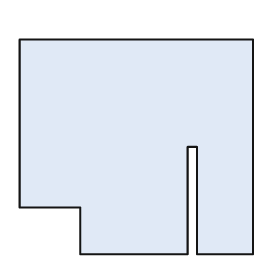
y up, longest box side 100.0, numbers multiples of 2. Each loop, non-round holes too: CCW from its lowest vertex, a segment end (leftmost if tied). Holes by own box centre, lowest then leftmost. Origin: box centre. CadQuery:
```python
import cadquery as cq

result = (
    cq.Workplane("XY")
    .moveTo(-24.0, -46.0)
    .lineTo(22.0, -46.0)
    .lineTo(22.0, 0.0)
    .lineTo(26.0, 0.0)
    .lineTo(26.0, -46.0)
    .lineTo(50.0, -46.0)
    .lineTo(50.0, 46.0)
    .lineTo(-50.0, 46.0)
    .lineTo(-50.0, -26.0)
    .lineTo(-24.0, -26.0)
    .close()
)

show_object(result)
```